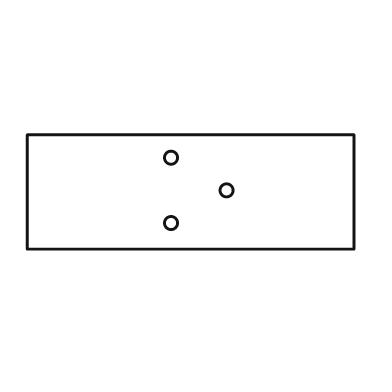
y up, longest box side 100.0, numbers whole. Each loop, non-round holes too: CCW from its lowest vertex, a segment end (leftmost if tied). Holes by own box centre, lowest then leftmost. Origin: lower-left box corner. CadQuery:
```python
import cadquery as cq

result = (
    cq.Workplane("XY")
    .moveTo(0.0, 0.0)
    .lineTo(100.0, 0.0)
    .lineTo(100.0, 35.0)
    .lineTo(0.0, 35.0)
    .close()
    .moveTo(44.0, 8.0)
    .circle(2.0)
    .moveTo(61.0, 18.0)
    .circle(2.0)
    .moveTo(44.0, 28.0)
    .circle(2.0)
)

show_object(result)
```